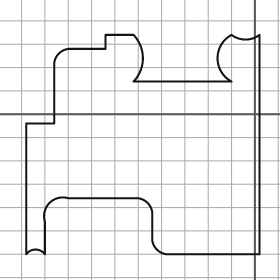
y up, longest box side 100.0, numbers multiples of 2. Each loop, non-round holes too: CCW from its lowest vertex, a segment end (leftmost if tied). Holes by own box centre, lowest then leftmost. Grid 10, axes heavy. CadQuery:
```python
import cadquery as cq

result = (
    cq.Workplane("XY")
    .moveTo(-98.0, -60.0)
    .threePointArc((-94.0, -58.0), (-90.0, -60.0))
    .lineTo(-90.0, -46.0)
    .threePointArc((-88.0, -38.0), (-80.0, -36.0))
    .lineTo(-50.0, -36.0)
    .threePointArc((-46.0, -38.0), (-44.0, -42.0))
    .lineTo(-44.0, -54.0)
    .threePointArc((-42.0, -58.0), (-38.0, -60.0))
    .lineTo(2.0, -60.0)
    .lineTo(2.0, 34.0)
    .threePointArc((-4.0, 32.0), (-10.0, 34.0))
    .threePointArc((-16.0, 24.0), (-10.0, 14.0))
    .lineTo(-52.0, 14.0)
    .threePointArc((-48.0, 24.0), (-52.0, 34.0))
    .lineTo(-64.0, 34.0)
    .lineTo(-64.0, 28.0)
    .lineTo(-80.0, 28.0)
    .threePointArc((-84.0, 26.0), (-86.0, 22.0))
    .lineTo(-86.0, -4.0)
    .lineTo(-98.0, -4.0)
    .close()
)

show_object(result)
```